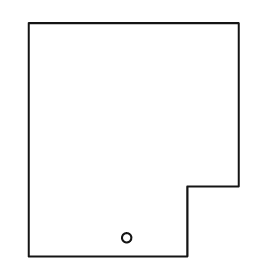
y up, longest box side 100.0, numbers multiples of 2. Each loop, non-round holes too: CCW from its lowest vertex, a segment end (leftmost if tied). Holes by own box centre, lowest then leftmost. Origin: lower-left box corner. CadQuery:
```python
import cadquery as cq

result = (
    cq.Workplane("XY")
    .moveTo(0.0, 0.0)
    .lineTo(68.0, 0.0)
    .lineTo(68.0, 30.0)
    .lineTo(90.0, 30.0)
    .lineTo(90.0, 100.0)
    .lineTo(0.0, 100.0)
    .close()
    .moveTo(42.0, 8.0)
    .circle(2.0)
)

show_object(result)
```